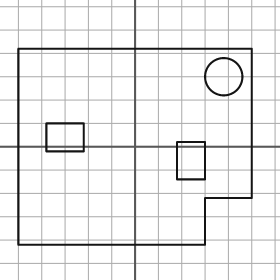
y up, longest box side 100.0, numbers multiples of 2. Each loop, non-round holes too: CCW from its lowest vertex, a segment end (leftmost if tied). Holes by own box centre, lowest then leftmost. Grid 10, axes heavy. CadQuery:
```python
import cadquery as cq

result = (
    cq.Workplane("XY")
    .moveTo(-50.0, -42.0)
    .lineTo(30.0, -42.0)
    .lineTo(30.0, -22.0)
    .lineTo(50.0, -22.0)
    .lineTo(50.0, 42.0)
    .lineTo(-50.0, 42.0)
    .close()
    .moveTo(18.0, -14.0)
    .lineTo(30.0, -14.0)
    .lineTo(30.0, 2.0)
    .lineTo(18.0, 2.0)
    .close()
    .moveTo(-38.0, -2.0)
    .lineTo(-22.0, -2.0)
    .lineTo(-22.0, 10.0)
    .lineTo(-38.0, 10.0)
    .close()
    .moveTo(38.0, 30.0)
    .circle(8.0)
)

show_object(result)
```